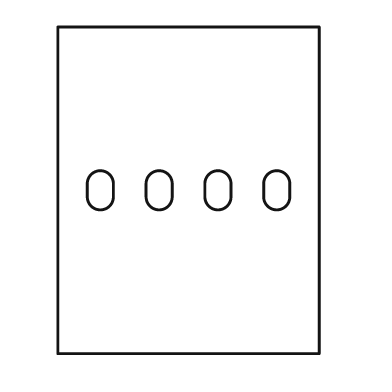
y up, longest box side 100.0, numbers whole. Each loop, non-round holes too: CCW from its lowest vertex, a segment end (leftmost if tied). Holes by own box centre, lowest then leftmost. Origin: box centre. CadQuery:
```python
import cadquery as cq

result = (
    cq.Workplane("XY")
    .moveTo(-40.0, -50.0)
    .lineTo(40.0, -50.0)
    .lineTo(40.0, 50.0)
    .lineTo(-40.0, 50.0)
    .close()
    .moveTo(-31.0, -2.0)
    .threePointArc((-27.0, -6.0), (-23.0, -2.0))
    .lineTo(-23.0, 2.0)
    .threePointArc((-27.0, 6.0), (-31.0, 2.0))
    .close()
    .moveTo(-13.0, -2.0)
    .threePointArc((-9.0, -6.0), (-5.0, -2.0))
    .lineTo(-5.0, 2.0)
    .threePointArc((-9.0, 6.0), (-13.0, 2.0))
    .close()
    .moveTo(5.0, -2.0)
    .threePointArc((9.0, -6.0), (13.0, -2.0))
    .lineTo(13.0, 2.0)
    .threePointArc((9.0, 6.0), (5.0, 2.0))
    .close()
    .moveTo(23.0, -2.0)
    .threePointArc((27.0, -6.0), (31.0, -2.0))
    .lineTo(31.0, 2.0)
    .threePointArc((27.0, 6.0), (23.0, 2.0))
    .close()
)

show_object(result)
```